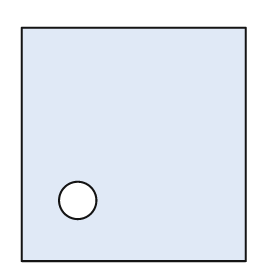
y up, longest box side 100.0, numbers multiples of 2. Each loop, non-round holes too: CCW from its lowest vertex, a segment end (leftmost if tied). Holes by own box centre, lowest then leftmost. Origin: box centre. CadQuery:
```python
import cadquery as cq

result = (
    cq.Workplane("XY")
    .moveTo(-48.0, -50.0)
    .lineTo(48.0, -50.0)
    .lineTo(48.0, 50.0)
    .lineTo(-48.0, 50.0)
    .close()
    .moveTo(-24.0, -24.0)
    .circle(8.0)
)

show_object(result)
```